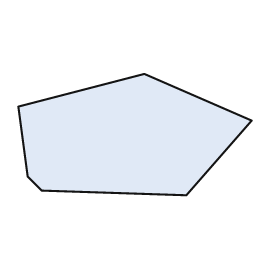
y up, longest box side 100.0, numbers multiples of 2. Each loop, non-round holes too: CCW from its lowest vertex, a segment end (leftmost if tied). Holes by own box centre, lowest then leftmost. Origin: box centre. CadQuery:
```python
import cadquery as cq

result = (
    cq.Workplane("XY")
    .moveTo(22.0, -26.0)
    .lineTo(50.0, 6.0)
    .lineTo(4.0, 26.0)
    .lineTo(-50.0, 12.0)
    .lineTo(-46.0, -18.0)
    .lineTo(-40.0, -24.0)
    .close()
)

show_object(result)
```